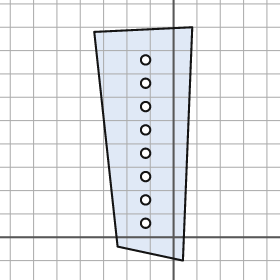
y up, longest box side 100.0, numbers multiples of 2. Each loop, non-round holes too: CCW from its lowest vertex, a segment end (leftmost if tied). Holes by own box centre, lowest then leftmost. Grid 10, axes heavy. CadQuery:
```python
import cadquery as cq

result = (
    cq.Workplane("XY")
    .moveTo(4.0, -10.0)
    .lineTo(8.0, 90.0)
    .lineTo(-34.0, 88.0)
    .lineTo(-24.0, -4.0)
    .close()
    .moveTo(-12.0, 6.0)
    .circle(2.0)
    .moveTo(-12.0, 16.0)
    .circle(2.0)
    .moveTo(-12.0, 26.0)
    .circle(2.0)
    .moveTo(-12.0, 36.0)
    .circle(2.0)
    .moveTo(-12.0, 46.0)
    .circle(2.0)
    .moveTo(-12.0, 56.0)
    .circle(2.0)
    .moveTo(-12.0, 66.0)
    .circle(2.0)
    .moveTo(-12.0, 76.0)
    .circle(2.0)
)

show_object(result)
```